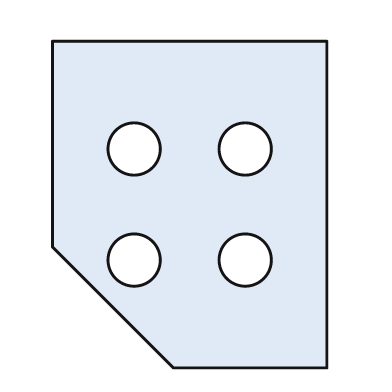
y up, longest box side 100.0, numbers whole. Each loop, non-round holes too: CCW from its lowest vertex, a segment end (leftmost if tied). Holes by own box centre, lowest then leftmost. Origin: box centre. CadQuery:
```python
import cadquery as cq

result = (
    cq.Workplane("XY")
    .moveTo(-5.0, -50.0)
    .lineTo(42.0, -50.0)
    .lineTo(42.0, 50.0)
    .lineTo(-42.0, 50.0)
    .lineTo(-42.0, -13.0)
    .close()
    .moveTo(-17.0, -17.0)
    .circle(8.0)
    .moveTo(17.0, -17.0)
    .circle(8.0)
    .moveTo(-17.0, 17.0)
    .circle(8.0)
    .moveTo(17.0, 17.0)
    .circle(8.0)
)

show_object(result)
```